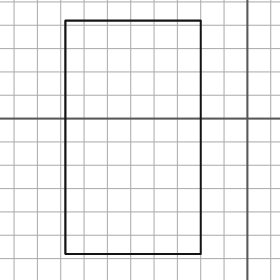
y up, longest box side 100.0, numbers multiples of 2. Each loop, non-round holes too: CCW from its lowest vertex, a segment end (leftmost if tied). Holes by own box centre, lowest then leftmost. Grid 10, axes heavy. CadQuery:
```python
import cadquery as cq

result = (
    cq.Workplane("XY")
    .moveTo(-78.0, -58.0)
    .lineTo(-20.0, -58.0)
    .lineTo(-20.0, 42.0)
    .lineTo(-78.0, 42.0)
    .close()
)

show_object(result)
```